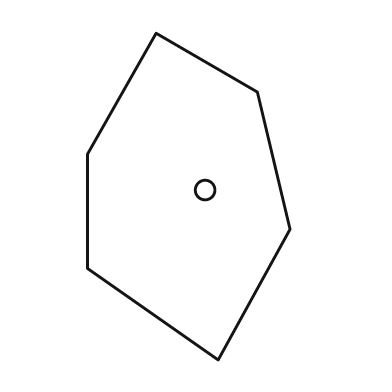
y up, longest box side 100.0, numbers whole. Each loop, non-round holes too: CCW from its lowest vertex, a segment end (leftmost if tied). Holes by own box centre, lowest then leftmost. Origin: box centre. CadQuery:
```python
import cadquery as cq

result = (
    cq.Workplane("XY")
    .moveTo(9.0, -50.0)
    .lineTo(31.0, -10.0)
    .lineTo(21.0, 32.0)
    .lineTo(-10.0, 50.0)
    .lineTo(-31.0, 13.0)
    .lineTo(-31.0, -22.0)
    .close()
    .moveTo(5.0, 2.0)
    .circle(3.0)
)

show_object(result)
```